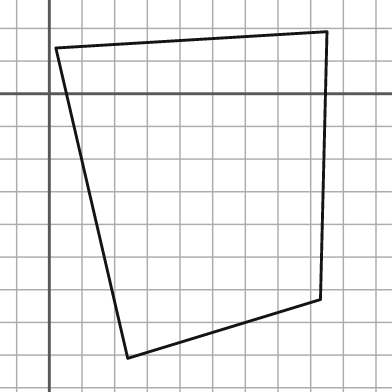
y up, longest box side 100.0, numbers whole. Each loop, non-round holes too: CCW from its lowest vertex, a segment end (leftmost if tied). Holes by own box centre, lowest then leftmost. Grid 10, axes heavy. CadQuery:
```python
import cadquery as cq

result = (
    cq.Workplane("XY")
    .moveTo(24.0, -81.0)
    .lineTo(83.0, -63.0)
    .lineTo(85.0, 19.0)
    .lineTo(2.0, 14.0)
    .close()
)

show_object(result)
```